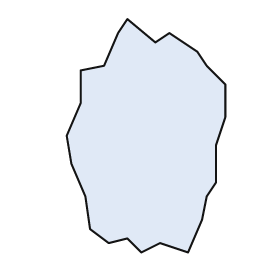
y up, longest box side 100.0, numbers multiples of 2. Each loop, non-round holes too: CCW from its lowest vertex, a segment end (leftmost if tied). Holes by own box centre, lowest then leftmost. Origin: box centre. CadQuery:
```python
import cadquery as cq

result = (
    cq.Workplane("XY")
    .moveTo(-2.0, -50.0)
    .lineTo(6.0, -46.0)
    .lineTo(18.0, -50.0)
    .lineTo(24.0, -36.0)
    .lineTo(26.0, -26.0)
    .lineTo(30.0, -20.0)
    .lineTo(30.0, -4.0)
    .lineTo(34.0, 8.0)
    .lineTo(34.0, 22.0)
    .lineTo(26.0, 30.0)
    .lineTo(22.0, 36.0)
    .lineTo(10.0, 44.0)
    .lineTo(4.0, 40.0)
    .lineTo(-8.0, 50.0)
    .lineTo(-12.0, 44.0)
    .lineTo(-18.0, 30.0)
    .lineTo(-28.0, 28.0)
    .lineTo(-28.0, 14.0)
    .lineTo(-34.0, 0.0)
    .lineTo(-32.0, -12.0)
    .lineTo(-26.0, -26.0)
    .lineTo(-24.0, -40.0)
    .lineTo(-16.0, -46.0)
    .lineTo(-8.0, -44.0)
    .close()
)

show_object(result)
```